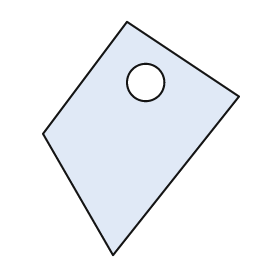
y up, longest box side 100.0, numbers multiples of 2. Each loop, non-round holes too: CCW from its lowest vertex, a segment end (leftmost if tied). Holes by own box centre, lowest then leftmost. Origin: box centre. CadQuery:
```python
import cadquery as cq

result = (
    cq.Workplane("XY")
    .moveTo(-12.0, -50.0)
    .lineTo(42.0, 18.0)
    .lineTo(-6.0, 50.0)
    .lineTo(-42.0, 2.0)
    .close()
    .moveTo(2.0, 24.0)
    .circle(8.0)
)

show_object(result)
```